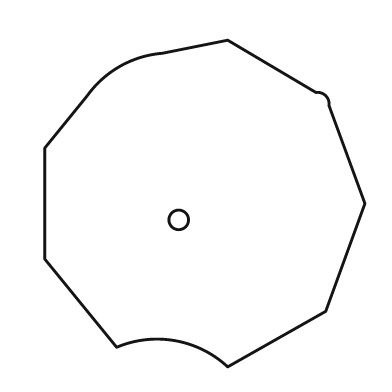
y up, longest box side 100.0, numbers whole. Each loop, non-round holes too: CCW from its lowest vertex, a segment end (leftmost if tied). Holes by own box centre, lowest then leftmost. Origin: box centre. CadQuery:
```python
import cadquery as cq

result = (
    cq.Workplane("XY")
    .moveTo(7.0, -50.0)
    .lineTo(37.0, -33.0)
    .lineTo(49.0, 0.0)
    .lineTo(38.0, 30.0)
    .threePointArc((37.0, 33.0), (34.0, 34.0))
    .lineTo(7.0, 50.0)
    .lineTo(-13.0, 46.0)
    .threePointArc((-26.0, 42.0), (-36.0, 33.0))
    .lineTo(-49.0, 17.0)
    .lineTo(-49.0, -17.0)
    .lineTo(-27.0, -44.0)
    .threePointArc((-9.0, -42.0), (7.0, -50.0))
    .close()
    .moveTo(-8.0, -5.0)
    .circle(3.0)
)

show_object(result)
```